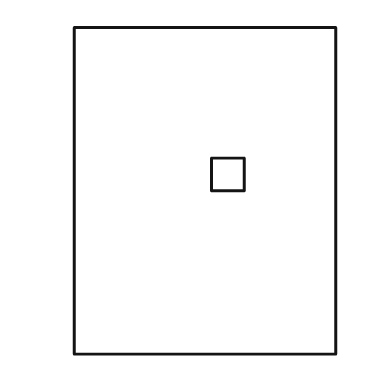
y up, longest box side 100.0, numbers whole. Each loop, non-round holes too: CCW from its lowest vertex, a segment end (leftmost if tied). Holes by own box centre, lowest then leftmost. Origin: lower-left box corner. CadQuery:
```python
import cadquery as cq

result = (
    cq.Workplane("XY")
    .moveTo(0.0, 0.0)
    .lineTo(80.0, 0.0)
    .lineTo(80.0, 100.0)
    .lineTo(0.0, 100.0)
    .close()
    .moveTo(42.0, 50.0)
    .lineTo(52.0, 50.0)
    .lineTo(52.0, 60.0)
    .lineTo(42.0, 60.0)
    .close()
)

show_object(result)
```